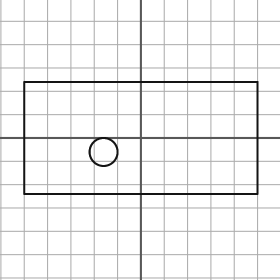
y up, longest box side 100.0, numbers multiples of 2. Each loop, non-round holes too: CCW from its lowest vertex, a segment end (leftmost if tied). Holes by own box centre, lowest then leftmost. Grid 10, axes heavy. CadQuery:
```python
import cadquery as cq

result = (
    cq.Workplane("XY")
    .moveTo(-50.0, -24.0)
    .lineTo(50.0, -24.0)
    .lineTo(50.0, 24.0)
    .lineTo(-50.0, 24.0)
    .close()
    .moveTo(-16.0, -6.0)
    .circle(6.0)
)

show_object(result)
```